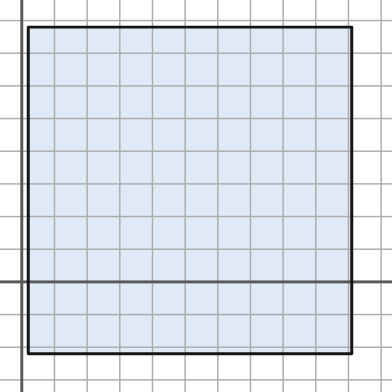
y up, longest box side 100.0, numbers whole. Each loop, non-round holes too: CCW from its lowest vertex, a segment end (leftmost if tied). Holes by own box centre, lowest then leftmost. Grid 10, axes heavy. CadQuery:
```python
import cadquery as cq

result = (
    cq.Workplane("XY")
    .moveTo(2.0, -22.0)
    .lineTo(101.0, -22.0)
    .lineTo(101.0, 78.0)
    .lineTo(2.0, 78.0)
    .close()
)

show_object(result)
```